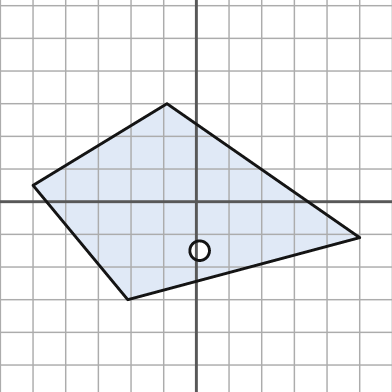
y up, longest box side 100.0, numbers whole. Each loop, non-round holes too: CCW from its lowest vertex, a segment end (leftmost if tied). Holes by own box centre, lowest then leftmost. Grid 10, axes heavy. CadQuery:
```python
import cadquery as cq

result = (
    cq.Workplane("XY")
    .moveTo(-21.0, -30.0)
    .lineTo(50.0, -11.0)
    .lineTo(-9.0, 30.0)
    .lineTo(-50.0, 5.0)
    .close()
    .moveTo(1.0, -15.0)
    .circle(3.0)
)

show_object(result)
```